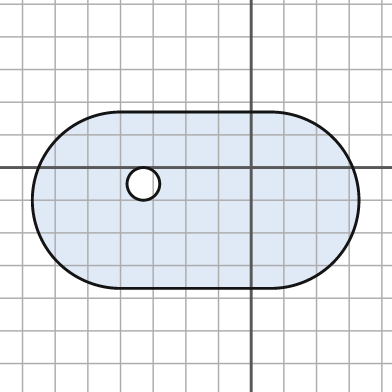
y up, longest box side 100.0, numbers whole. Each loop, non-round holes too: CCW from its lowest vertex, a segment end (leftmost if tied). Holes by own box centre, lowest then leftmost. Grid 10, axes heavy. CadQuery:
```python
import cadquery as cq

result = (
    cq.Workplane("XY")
    .moveTo(-40.0, -37.0)
    .lineTo(6.0, -37.0)
    .threePointArc((33.0, -10.0), (6.0, 17.0))
    .lineTo(-40.0, 17.0)
    .threePointArc((-67.0, -10.0), (-40.0, -37.0))
    .close()
    .moveTo(-33.0, -5.0)
    .circle(5.0)
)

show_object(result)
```